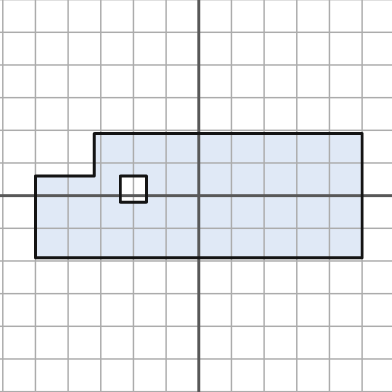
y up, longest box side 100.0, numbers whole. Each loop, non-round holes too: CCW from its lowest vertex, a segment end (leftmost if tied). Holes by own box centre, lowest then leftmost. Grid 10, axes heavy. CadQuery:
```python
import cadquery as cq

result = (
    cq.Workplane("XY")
    .moveTo(-50.0, -19.0)
    .lineTo(50.0, -19.0)
    .lineTo(50.0, 19.0)
    .lineTo(-32.0, 19.0)
    .lineTo(-32.0, 6.0)
    .lineTo(-50.0, 6.0)
    .close()
    .moveTo(-24.0, -2.0)
    .lineTo(-16.0, -2.0)
    .lineTo(-16.0, 6.0)
    .lineTo(-24.0, 6.0)
    .close()
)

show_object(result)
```